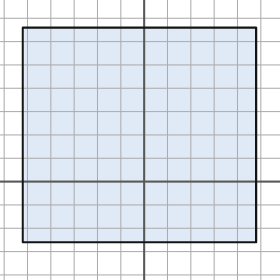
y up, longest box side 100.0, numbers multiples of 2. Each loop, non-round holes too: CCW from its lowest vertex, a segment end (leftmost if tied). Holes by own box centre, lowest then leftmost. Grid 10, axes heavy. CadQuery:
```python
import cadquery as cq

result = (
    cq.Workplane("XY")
    .moveTo(-52.0, -26.0)
    .lineTo(48.0, -26.0)
    .lineTo(48.0, 66.0)
    .lineTo(-52.0, 66.0)
    .close()
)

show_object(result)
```